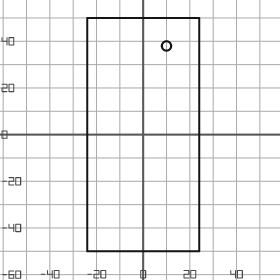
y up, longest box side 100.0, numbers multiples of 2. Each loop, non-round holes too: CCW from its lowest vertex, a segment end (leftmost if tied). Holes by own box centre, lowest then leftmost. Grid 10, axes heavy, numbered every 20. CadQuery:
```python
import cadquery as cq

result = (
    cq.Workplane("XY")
    .moveTo(-24.0, -50.0)
    .lineTo(24.0, -50.0)
    .lineTo(24.0, 50.0)
    .lineTo(-24.0, 50.0)
    .close()
    .moveTo(10.0, 38.0)
    .circle(2.0)
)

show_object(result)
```